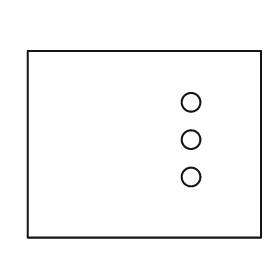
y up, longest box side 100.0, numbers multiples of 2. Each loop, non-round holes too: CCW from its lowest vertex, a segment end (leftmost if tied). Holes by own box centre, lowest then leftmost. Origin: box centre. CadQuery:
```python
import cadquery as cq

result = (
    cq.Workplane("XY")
    .moveTo(-50.0, -40.0)
    .lineTo(50.0, -40.0)
    .lineTo(50.0, 40.0)
    .lineTo(-50.0, 40.0)
    .close()
    .moveTo(20.0, -14.0)
    .circle(4.0)
    .moveTo(20.0, 2.0)
    .circle(4.0)
    .moveTo(20.0, 18.0)
    .circle(4.0)
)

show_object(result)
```